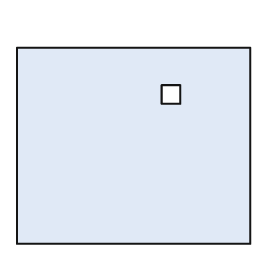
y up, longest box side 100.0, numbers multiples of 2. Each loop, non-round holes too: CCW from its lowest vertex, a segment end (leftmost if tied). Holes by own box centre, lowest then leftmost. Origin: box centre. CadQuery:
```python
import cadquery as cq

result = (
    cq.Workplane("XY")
    .moveTo(-50.0, -42.0)
    .lineTo(50.0, -42.0)
    .lineTo(50.0, 42.0)
    .lineTo(-50.0, 42.0)
    .close()
    .moveTo(12.0, 18.0)
    .lineTo(20.0, 18.0)
    .lineTo(20.0, 26.0)
    .lineTo(12.0, 26.0)
    .close()
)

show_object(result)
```